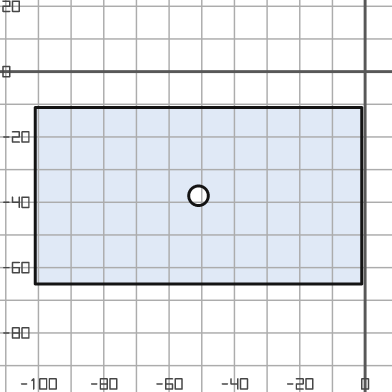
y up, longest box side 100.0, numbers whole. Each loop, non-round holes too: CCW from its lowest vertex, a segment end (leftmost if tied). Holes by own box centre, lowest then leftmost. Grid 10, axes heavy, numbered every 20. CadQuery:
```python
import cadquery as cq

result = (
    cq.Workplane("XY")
    .moveTo(-101.0, -65.0)
    .lineTo(-1.0, -65.0)
    .lineTo(-1.0, -11.0)
    .lineTo(-101.0, -11.0)
    .close()
    .moveTo(-51.0, -38.0)
    .circle(3.0)
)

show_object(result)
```